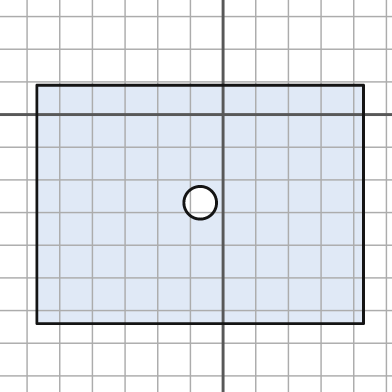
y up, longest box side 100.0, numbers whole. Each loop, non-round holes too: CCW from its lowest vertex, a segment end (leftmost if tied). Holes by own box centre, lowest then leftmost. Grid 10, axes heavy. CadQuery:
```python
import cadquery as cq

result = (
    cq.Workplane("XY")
    .moveTo(-57.0, -64.0)
    .lineTo(43.0, -64.0)
    .lineTo(43.0, 9.0)
    .lineTo(-57.0, 9.0)
    .close()
    .moveTo(-7.0, -27.0)
    .circle(5.0)
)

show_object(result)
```